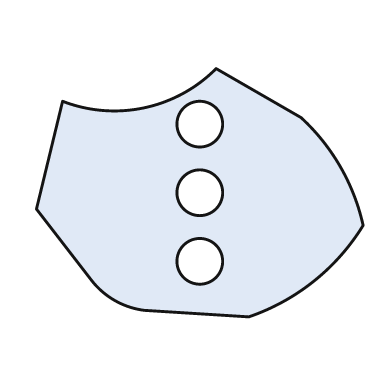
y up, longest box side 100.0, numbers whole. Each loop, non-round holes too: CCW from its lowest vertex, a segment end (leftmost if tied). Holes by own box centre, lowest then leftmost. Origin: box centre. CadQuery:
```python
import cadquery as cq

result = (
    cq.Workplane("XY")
    .moveTo(15.0, -38.0)
    .threePointArc((35.0, -27.0), (50.0, -10.0))
    .threePointArc((43.0, 8.0), (31.0, 23.0))
    .lineTo(5.0, 38.0)
    .threePointArc((-17.0, 26.0), (-42.0, 28.0))
    .lineTo(-50.0, -5.0)
    .lineTo(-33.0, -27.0)
    .threePointArc((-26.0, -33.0), (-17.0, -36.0))
    .close()
    .moveTo(0.0, -21.0)
    .circle(7.0)
    .moveTo(0.0, 0.0)
    .circle(7.0)
    .moveTo(0.0, 21.0)
    .circle(7.0)
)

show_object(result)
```